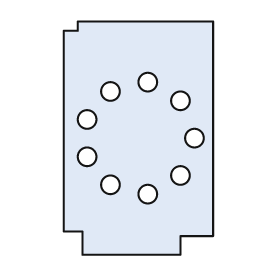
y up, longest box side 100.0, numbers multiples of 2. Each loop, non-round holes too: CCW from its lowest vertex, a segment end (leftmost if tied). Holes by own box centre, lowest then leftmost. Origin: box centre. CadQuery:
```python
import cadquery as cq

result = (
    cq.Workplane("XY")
    .moveTo(-24.0, -50.0)
    .lineTo(18.0, -50.0)
    .lineTo(18.0, -42.0)
    .lineTo(32.0, -42.0)
    .lineTo(32.0, 50.0)
    .lineTo(-26.0, 50.0)
    .lineTo(-26.0, 46.0)
    .lineTo(-32.0, 46.0)
    .lineTo(-32.0, -40.0)
    .lineTo(-24.0, -40.0)
    .close()
    .moveTo(4.0, -24.0)
    .circle(4.0)
    .moveTo(-12.0, -20.0)
    .circle(4.0)
    .moveTo(18.0, -16.0)
    .circle(4.0)
    .moveTo(-22.0, -8.0)
    .circle(4.0)
    .moveTo(24.0, 0.0)
    .circle(4.0)
    .moveTo(-22.0, 8.0)
    .circle(4.0)
    .moveTo(18.0, 16.0)
    .circle(4.0)
    .moveTo(-12.0, 20.0)
    .circle(4.0)
    .moveTo(4.0, 24.0)
    .circle(4.0)
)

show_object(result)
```